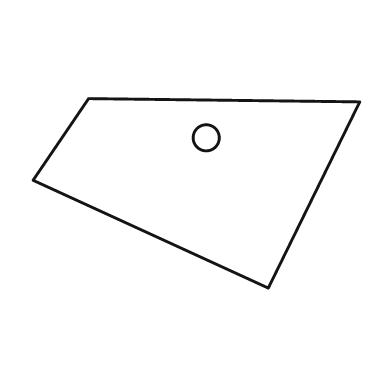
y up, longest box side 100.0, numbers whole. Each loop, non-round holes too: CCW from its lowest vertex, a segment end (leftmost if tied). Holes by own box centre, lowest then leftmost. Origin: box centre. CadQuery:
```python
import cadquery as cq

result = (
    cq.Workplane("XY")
    .moveTo(22.0, -29.0)
    .lineTo(50.0, 28.0)
    .lineTo(-33.0, 29.0)
    .lineTo(-50.0, 4.0)
    .close()
    .moveTo(3.0, 17.0)
    .circle(4.0)
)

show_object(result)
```